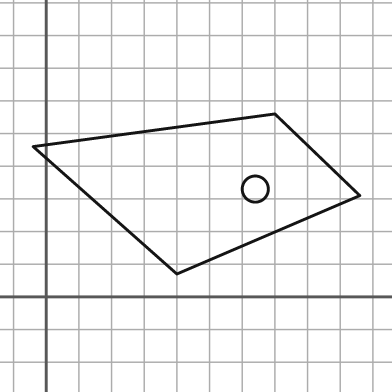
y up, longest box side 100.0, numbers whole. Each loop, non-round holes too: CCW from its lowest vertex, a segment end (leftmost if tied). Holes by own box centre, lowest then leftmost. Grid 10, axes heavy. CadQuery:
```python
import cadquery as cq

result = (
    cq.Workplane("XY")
    .moveTo(40.0, 7.0)
    .lineTo(96.0, 31.0)
    .lineTo(70.0, 56.0)
    .lineTo(-4.0, 46.0)
    .close()
    .moveTo(64.0, 33.0)
    .circle(4.0)
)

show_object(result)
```